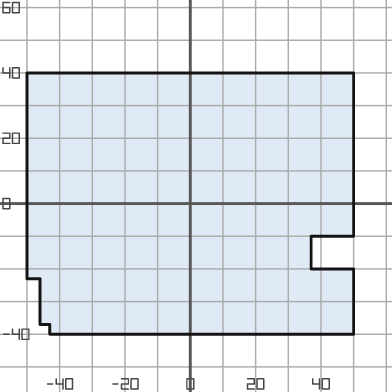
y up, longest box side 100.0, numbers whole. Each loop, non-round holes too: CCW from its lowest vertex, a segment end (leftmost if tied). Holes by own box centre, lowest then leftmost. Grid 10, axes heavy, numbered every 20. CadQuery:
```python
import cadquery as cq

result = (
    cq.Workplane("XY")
    .moveTo(-43.0, -40.0)
    .lineTo(50.0, -40.0)
    .lineTo(50.0, -20.0)
    .lineTo(37.0, -20.0)
    .lineTo(37.0, -10.0)
    .lineTo(50.0, -10.0)
    .lineTo(50.0, 40.0)
    .lineTo(-50.0, 40.0)
    .lineTo(-50.0, -23.0)
    .lineTo(-46.0, -23.0)
    .lineTo(-46.0, -37.0)
    .lineTo(-43.0, -37.0)
    .close()
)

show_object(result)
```